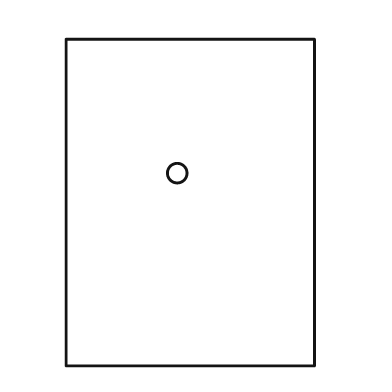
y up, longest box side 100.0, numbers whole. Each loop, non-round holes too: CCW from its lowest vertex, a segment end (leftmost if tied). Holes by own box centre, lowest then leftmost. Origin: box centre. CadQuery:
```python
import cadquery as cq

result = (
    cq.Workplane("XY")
    .moveTo(-38.0, -50.0)
    .lineTo(38.0, -50.0)
    .lineTo(38.0, 50.0)
    .lineTo(-38.0, 50.0)
    .close()
    .moveTo(-4.0, 9.0)
    .circle(3.0)
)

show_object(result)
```